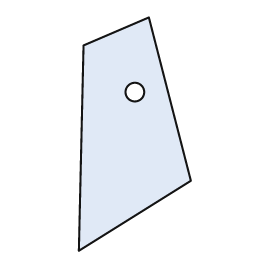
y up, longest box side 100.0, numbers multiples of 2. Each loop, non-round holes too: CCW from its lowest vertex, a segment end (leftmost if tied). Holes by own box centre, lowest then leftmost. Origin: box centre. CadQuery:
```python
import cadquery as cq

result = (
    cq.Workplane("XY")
    .moveTo(-24.0, -50.0)
    .lineTo(24.0, -20.0)
    .lineTo(6.0, 50.0)
    .lineTo(-22.0, 38.0)
    .close()
    .moveTo(0.0, 18.0)
    .circle(4.0)
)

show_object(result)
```